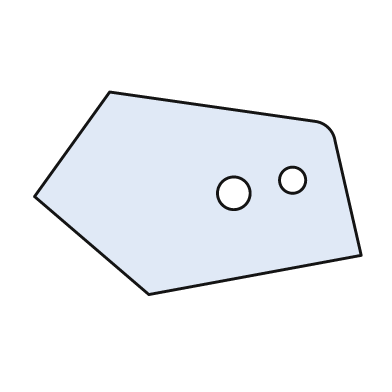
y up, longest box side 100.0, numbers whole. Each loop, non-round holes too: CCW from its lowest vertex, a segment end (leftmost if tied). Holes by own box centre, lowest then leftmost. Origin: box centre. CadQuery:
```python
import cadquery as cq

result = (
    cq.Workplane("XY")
    .moveTo(-15.0, -31.0)
    .lineTo(50.0, -19.0)
    .lineTo(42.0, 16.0)
    .threePointArc((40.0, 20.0), (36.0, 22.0))
    .lineTo(-27.0, 31.0)
    .lineTo(-50.0, -1.0)
    .close()
    .moveTo(11.0, 0.0)
    .circle(5.0)
    .moveTo(29.0, 4.0)
    .circle(4.0)
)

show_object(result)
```